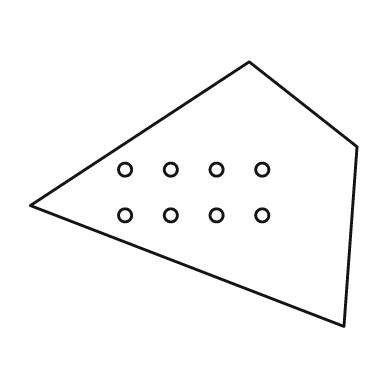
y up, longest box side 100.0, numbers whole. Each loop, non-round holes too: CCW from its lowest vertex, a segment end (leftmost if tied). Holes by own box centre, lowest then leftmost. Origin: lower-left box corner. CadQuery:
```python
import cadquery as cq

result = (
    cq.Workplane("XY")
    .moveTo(96.0, 0.0)
    .lineTo(100.0, 55.0)
    .lineTo(67.0, 81.0)
    .lineTo(0.0, 37.0)
    .close()
    .moveTo(29.0, 34.0)
    .circle(2.0)
    .moveTo(43.0, 34.0)
    .circle(2.0)
    .moveTo(57.0, 34.0)
    .circle(2.0)
    .moveTo(71.0, 34.0)
    .circle(2.0)
    .moveTo(29.0, 48.0)
    .circle(2.0)
    .moveTo(43.0, 48.0)
    .circle(2.0)
    .moveTo(57.0, 48.0)
    .circle(2.0)
    .moveTo(71.0, 48.0)
    .circle(2.0)
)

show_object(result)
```